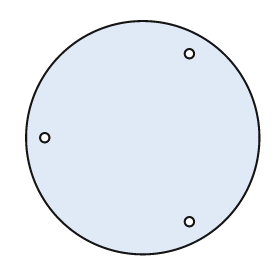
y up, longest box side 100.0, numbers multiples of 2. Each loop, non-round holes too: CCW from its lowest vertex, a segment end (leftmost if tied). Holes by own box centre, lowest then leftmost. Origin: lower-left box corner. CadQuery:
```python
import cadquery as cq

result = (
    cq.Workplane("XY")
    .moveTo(50.0, 50.0)
    .circle(50.0)
    .moveTo(70.0, 14.0)
    .circle(2.0)
    .moveTo(8.0, 50.0)
    .circle(2.0)
    .moveTo(70.0, 86.0)
    .circle(2.0)
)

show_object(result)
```